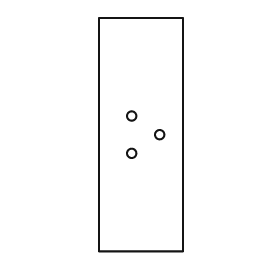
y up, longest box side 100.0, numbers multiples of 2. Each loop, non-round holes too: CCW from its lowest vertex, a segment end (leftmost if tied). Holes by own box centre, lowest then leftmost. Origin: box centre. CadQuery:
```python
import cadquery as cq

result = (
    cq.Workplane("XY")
    .moveTo(-18.0, -50.0)
    .lineTo(18.0, -50.0)
    .lineTo(18.0, 50.0)
    .lineTo(-18.0, 50.0)
    .close()
    .moveTo(-4.0, -8.0)
    .circle(2.0)
    .moveTo(8.0, 0.0)
    .circle(2.0)
    .moveTo(-4.0, 8.0)
    .circle(2.0)
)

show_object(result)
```